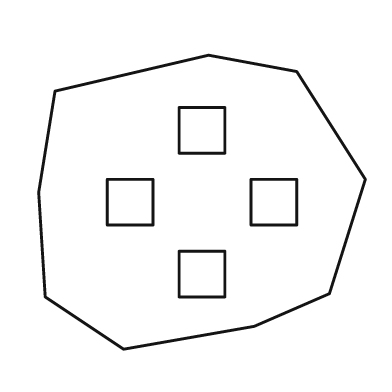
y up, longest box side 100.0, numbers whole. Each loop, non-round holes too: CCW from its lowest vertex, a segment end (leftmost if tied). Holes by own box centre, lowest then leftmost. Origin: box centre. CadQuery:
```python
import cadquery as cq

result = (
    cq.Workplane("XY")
    .moveTo(-24.0, -45.0)
    .lineTo(16.0, -38.0)
    .lineTo(39.0, -28.0)
    .lineTo(50.0, 7.0)
    .lineTo(29.0, 40.0)
    .lineTo(2.0, 45.0)
    .lineTo(-45.0, 34.0)
    .lineTo(-50.0, 3.0)
    .lineTo(-48.0, -29.0)
    .close()
    .moveTo(-7.0, -29.0)
    .lineTo(7.0, -29.0)
    .lineTo(7.0, -15.0)
    .lineTo(-7.0, -15.0)
    .close()
    .moveTo(-29.0, -7.0)
    .lineTo(-15.0, -7.0)
    .lineTo(-15.0, 7.0)
    .lineTo(-29.0, 7.0)
    .close()
    .moveTo(15.0, -7.0)
    .lineTo(29.0, -7.0)
    .lineTo(29.0, 7.0)
    .lineTo(15.0, 7.0)
    .close()
    .moveTo(-7.0, 15.0)
    .lineTo(7.0, 15.0)
    .lineTo(7.0, 29.0)
    .lineTo(-7.0, 29.0)
    .close()
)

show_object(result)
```